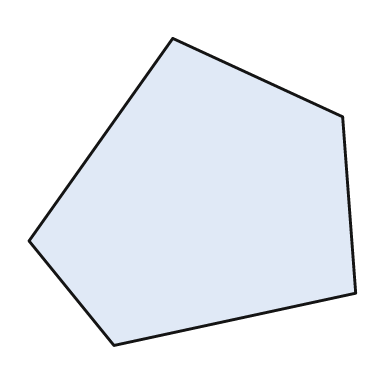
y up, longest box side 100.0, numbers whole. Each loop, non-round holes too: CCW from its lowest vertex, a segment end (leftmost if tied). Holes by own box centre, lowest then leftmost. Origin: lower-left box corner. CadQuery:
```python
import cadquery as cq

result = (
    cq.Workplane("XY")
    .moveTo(26.0, 0.0)
    .lineTo(100.0, 16.0)
    .lineTo(96.0, 70.0)
    .lineTo(44.0, 94.0)
    .lineTo(0.0, 32.0)
    .close()
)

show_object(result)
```